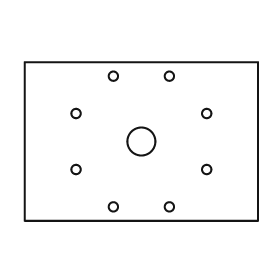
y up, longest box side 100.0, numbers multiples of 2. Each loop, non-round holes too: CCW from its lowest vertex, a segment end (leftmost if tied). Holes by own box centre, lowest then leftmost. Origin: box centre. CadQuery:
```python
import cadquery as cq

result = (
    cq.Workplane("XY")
    .moveTo(-50.0, -34.0)
    .lineTo(50.0, -34.0)
    .lineTo(50.0, 34.0)
    .lineTo(-50.0, 34.0)
    .close()
    .moveTo(-12.0, -28.0)
    .circle(2.0)
    .moveTo(12.0, -28.0)
    .circle(2.0)
    .moveTo(-28.0, -12.0)
    .circle(2.0)
    .moveTo(28.0, -12.0)
    .circle(2.0)
    .moveTo(0.0, 0.0)
    .circle(6.0)
    .moveTo(-28.0, 12.0)
    .circle(2.0)
    .moveTo(28.0, 12.0)
    .circle(2.0)
    .moveTo(-12.0, 28.0)
    .circle(2.0)
    .moveTo(12.0, 28.0)
    .circle(2.0)
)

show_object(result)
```